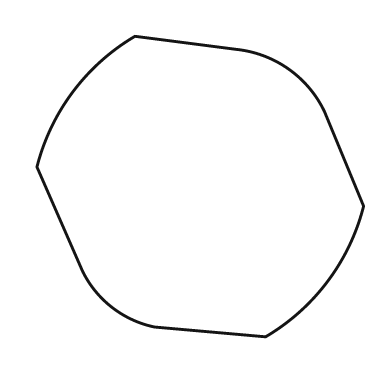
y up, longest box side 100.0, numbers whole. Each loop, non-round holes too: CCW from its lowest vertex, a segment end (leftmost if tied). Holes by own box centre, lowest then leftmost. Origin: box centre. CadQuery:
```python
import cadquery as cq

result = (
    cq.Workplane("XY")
    .moveTo(20.0, -46.0)
    .threePointArc((39.0, -29.0), (50.0, -6.0))
    .lineTo(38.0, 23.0)
    .threePointArc((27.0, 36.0), (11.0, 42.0))
    .lineTo(-20.0, 46.0)
    .threePointArc((-39.0, 29.0), (-50.0, 6.0))
    .lineTo(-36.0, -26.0)
    .threePointArc((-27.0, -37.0), (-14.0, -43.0))
    .close()
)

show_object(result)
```